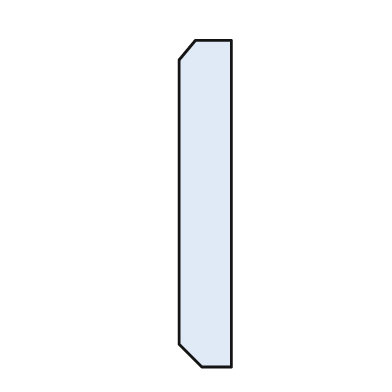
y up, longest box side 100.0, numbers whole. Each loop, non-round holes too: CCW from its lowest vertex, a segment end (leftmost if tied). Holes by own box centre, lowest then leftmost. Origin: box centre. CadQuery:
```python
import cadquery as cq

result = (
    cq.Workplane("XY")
    .moveTo(-1.0, -50.0)
    .lineTo(8.0, -50.0)
    .lineTo(8.0, 50.0)
    .lineTo(-3.0, 50.0)
    .lineTo(-8.0, 44.0)
    .lineTo(-8.0, -43.0)
    .close()
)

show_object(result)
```